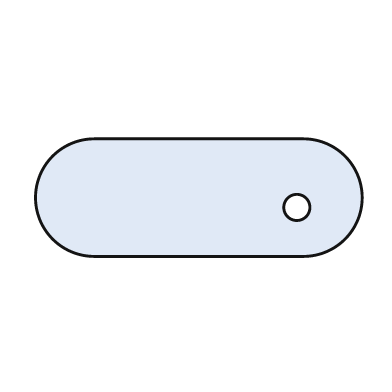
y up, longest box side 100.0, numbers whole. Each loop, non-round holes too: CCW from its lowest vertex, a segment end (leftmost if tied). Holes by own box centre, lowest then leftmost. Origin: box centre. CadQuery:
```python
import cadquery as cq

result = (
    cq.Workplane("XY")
    .moveTo(-32.0, -18.0)
    .lineTo(32.0, -18.0)
    .threePointArc((50.0, 0.0), (32.0, 18.0))
    .lineTo(-32.0, 18.0)
    .threePointArc((-50.0, 0.0), (-32.0, -18.0))
    .close()
    .moveTo(30.0, -3.0)
    .circle(4.0)
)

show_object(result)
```